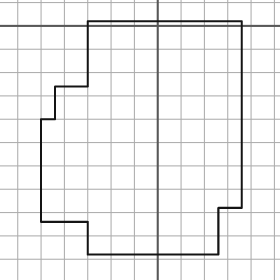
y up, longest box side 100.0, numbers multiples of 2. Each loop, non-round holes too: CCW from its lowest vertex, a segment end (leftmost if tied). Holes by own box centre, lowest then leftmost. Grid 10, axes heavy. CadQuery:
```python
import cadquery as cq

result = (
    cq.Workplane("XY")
    .moveTo(-30.0, -98.0)
    .lineTo(26.0, -98.0)
    .lineTo(26.0, -78.0)
    .lineTo(36.0, -78.0)
    .lineTo(36.0, 2.0)
    .lineTo(-30.0, 2.0)
    .lineTo(-30.0, -26.0)
    .lineTo(-44.0, -26.0)
    .lineTo(-44.0, -40.0)
    .lineTo(-50.0, -40.0)
    .lineTo(-50.0, -84.0)
    .lineTo(-30.0, -84.0)
    .close()
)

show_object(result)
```